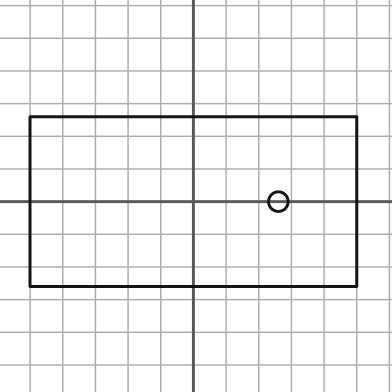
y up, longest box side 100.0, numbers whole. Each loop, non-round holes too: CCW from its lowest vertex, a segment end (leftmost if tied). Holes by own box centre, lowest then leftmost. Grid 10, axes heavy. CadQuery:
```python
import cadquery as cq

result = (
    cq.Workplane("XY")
    .moveTo(-50.0, -26.0)
    .lineTo(50.0, -26.0)
    .lineTo(50.0, 26.0)
    .lineTo(-50.0, 26.0)
    .close()
    .moveTo(26.0, 0.0)
    .circle(3.0)
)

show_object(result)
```